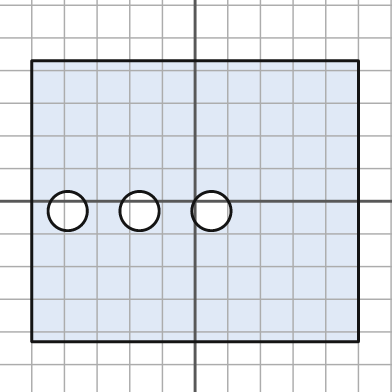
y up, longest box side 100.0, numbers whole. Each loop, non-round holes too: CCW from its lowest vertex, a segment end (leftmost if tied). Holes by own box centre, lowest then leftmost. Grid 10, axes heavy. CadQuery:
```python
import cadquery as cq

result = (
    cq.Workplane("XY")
    .moveTo(-50.0, -43.0)
    .lineTo(50.0, -43.0)
    .lineTo(50.0, 43.0)
    .lineTo(-50.0, 43.0)
    .close()
    .moveTo(-39.0, -3.0)
    .circle(6.0)
    .moveTo(-17.0, -3.0)
    .circle(6.0)
    .moveTo(5.0, -3.0)
    .circle(6.0)
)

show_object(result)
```